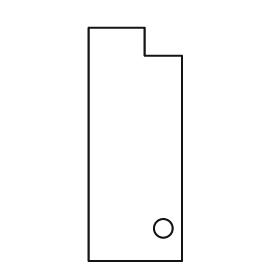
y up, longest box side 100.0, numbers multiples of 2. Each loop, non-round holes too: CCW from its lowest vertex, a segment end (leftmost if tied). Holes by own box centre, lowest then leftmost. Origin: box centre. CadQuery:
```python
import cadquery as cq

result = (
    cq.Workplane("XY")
    .moveTo(-20.0, -50.0)
    .lineTo(20.0, -50.0)
    .lineTo(20.0, 38.0)
    .lineTo(4.0, 38.0)
    .lineTo(4.0, 50.0)
    .lineTo(-20.0, 50.0)
    .close()
    .moveTo(12.0, -36.0)
    .circle(4.0)
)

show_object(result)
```